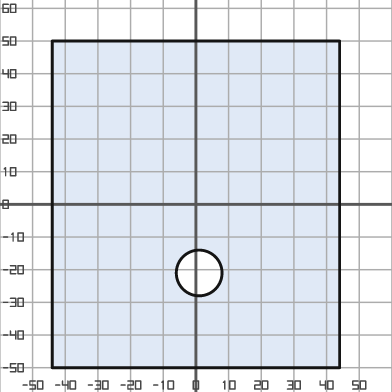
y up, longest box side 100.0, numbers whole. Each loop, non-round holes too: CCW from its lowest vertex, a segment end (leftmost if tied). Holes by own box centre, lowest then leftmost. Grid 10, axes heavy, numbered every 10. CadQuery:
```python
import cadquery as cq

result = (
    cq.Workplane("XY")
    .moveTo(-44.0, -50.0)
    .lineTo(44.0, -50.0)
    .lineTo(44.0, 50.0)
    .lineTo(-44.0, 50.0)
    .close()
    .moveTo(1.0, -21.0)
    .circle(7.0)
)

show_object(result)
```